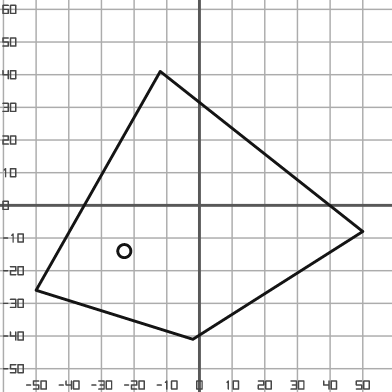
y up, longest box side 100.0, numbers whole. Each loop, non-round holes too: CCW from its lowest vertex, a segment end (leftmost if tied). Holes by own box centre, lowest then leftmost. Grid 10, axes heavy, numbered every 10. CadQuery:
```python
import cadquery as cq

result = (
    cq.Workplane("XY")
    .moveTo(-2.0, -41.0)
    .lineTo(50.0, -8.0)
    .lineTo(-12.0, 41.0)
    .lineTo(-50.0, -26.0)
    .close()
    .moveTo(-23.0, -14.0)
    .circle(2.0)
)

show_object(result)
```